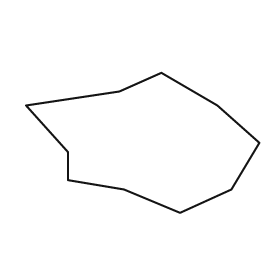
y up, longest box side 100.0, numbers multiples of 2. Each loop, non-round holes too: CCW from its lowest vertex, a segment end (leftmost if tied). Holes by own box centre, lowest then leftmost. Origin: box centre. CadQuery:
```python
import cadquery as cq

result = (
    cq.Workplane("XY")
    .moveTo(16.0, -30.0)
    .lineTo(38.0, -20.0)
    .lineTo(50.0, 0.0)
    .lineTo(32.0, 16.0)
    .lineTo(8.0, 30.0)
    .lineTo(-10.0, 22.0)
    .lineTo(-50.0, 16.0)
    .lineTo(-32.0, -4.0)
    .lineTo(-32.0, -16.0)
    .lineTo(-8.0, -20.0)
    .close()
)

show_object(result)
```